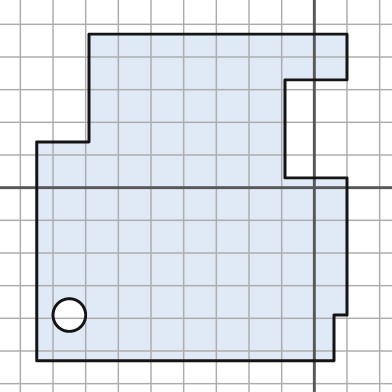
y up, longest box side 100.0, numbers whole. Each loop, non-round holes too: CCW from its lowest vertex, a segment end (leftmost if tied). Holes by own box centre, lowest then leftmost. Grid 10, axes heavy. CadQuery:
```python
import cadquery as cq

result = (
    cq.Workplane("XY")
    .moveTo(-85.0, -53.0)
    .lineTo(6.0, -53.0)
    .lineTo(6.0, -39.0)
    .lineTo(10.0, -39.0)
    .lineTo(10.0, 3.0)
    .lineTo(-9.0, 3.0)
    .lineTo(-9.0, 33.0)
    .lineTo(10.0, 33.0)
    .lineTo(10.0, 47.0)
    .lineTo(-69.0, 47.0)
    .lineTo(-69.0, 14.0)
    .lineTo(-85.0, 14.0)
    .close()
    .moveTo(-75.0, -39.0)
    .circle(5.0)
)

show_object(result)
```